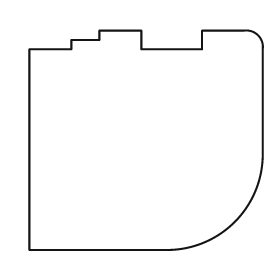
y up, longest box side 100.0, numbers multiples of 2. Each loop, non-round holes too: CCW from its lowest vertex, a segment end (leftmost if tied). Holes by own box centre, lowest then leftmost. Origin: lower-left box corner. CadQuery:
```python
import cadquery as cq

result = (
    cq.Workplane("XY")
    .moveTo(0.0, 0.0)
    .lineTo(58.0, 0.0)
    .threePointArc((88.0, 12.0), (100.0, 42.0))
    .lineTo(100.0, 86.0)
    .threePointArc((98.0, 92.0), (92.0, 94.0))
    .lineTo(74.0, 94.0)
    .lineTo(74.0, 86.0)
    .lineTo(48.0, 86.0)
    .lineTo(48.0, 94.0)
    .lineTo(30.0, 94.0)
    .lineTo(30.0, 90.0)
    .lineTo(18.0, 90.0)
    .lineTo(18.0, 86.0)
    .lineTo(0.0, 86.0)
    .close()
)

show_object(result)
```